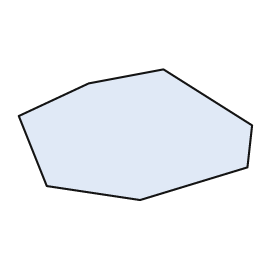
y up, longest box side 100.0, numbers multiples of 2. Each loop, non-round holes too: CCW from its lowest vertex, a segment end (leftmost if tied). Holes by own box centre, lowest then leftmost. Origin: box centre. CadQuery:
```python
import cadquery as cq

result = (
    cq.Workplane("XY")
    .moveTo(2.0, -28.0)
    .lineTo(48.0, -14.0)
    .lineTo(50.0, 4.0)
    .lineTo(12.0, 28.0)
    .lineTo(-20.0, 22.0)
    .lineTo(-50.0, 8.0)
    .lineTo(-38.0, -22.0)
    .close()
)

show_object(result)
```